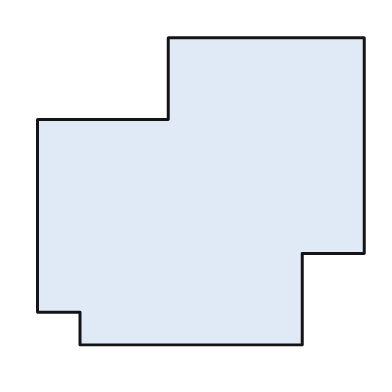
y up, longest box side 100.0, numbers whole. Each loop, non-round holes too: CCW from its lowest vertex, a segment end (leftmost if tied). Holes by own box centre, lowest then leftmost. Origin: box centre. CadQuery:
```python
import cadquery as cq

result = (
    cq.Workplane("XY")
    .moveTo(-37.0, -47.0)
    .lineTo(31.0, -47.0)
    .lineTo(31.0, -19.0)
    .lineTo(50.0, -19.0)
    .lineTo(50.0, 47.0)
    .lineTo(-10.0, 47.0)
    .lineTo(-10.0, 22.0)
    .lineTo(-50.0, 22.0)
    .lineTo(-50.0, -37.0)
    .lineTo(-37.0, -37.0)
    .close()
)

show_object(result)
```